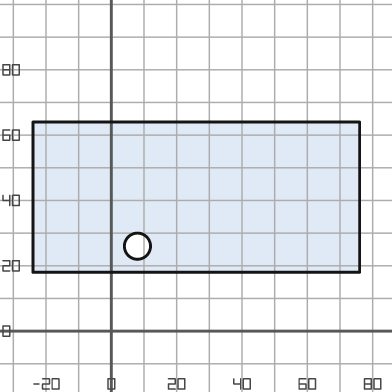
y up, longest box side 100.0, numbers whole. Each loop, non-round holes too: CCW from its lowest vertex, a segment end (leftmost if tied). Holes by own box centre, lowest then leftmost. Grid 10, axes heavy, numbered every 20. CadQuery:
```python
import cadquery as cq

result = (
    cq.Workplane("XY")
    .moveTo(-24.0, 18.0)
    .lineTo(76.0, 18.0)
    .lineTo(76.0, 64.0)
    .lineTo(-24.0, 64.0)
    .close()
    .moveTo(8.0, 26.0)
    .circle(4.0)
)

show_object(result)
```